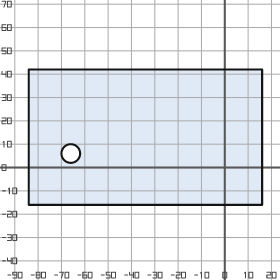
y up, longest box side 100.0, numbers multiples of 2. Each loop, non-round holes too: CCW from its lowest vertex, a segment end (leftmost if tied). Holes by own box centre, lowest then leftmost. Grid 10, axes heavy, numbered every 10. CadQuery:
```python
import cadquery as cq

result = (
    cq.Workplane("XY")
    .moveTo(-84.0, -16.0)
    .lineTo(16.0, -16.0)
    .lineTo(16.0, 42.0)
    .lineTo(-84.0, 42.0)
    .close()
    .moveTo(-66.0, 6.0)
    .circle(4.0)
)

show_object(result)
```